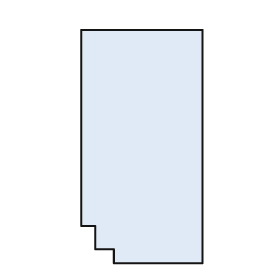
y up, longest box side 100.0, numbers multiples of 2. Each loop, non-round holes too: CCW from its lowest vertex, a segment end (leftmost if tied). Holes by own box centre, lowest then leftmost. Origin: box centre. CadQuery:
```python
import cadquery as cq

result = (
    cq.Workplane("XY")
    .moveTo(-12.0, -50.0)
    .lineTo(26.0, -50.0)
    .lineTo(26.0, 50.0)
    .lineTo(-26.0, 50.0)
    .lineTo(-26.0, -34.0)
    .lineTo(-20.0, -34.0)
    .lineTo(-20.0, -44.0)
    .lineTo(-12.0, -44.0)
    .close()
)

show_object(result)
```